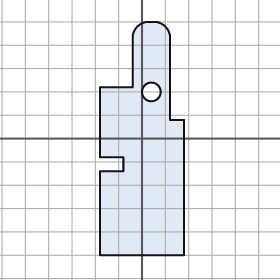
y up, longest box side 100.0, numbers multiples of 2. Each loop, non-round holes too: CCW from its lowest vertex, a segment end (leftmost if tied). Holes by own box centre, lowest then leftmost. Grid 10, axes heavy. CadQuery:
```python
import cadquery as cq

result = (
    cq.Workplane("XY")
    .moveTo(-18.0, -50.0)
    .lineTo(18.0, -50.0)
    .lineTo(18.0, 8.0)
    .lineTo(12.0, 8.0)
    .lineTo(12.0, 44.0)
    .threePointArc((10.0, 48.0), (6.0, 50.0))
    .lineTo(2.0, 50.0)
    .threePointArc((-2.0, 48.0), (-4.0, 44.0))
    .lineTo(-4.0, 22.0)
    .lineTo(-18.0, 22.0)
    .lineTo(-18.0, -8.0)
    .lineTo(-8.0, -8.0)
    .lineTo(-8.0, -14.0)
    .lineTo(-18.0, -14.0)
    .close()
    .moveTo(4.0, 20.0)
    .circle(4.0)
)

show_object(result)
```